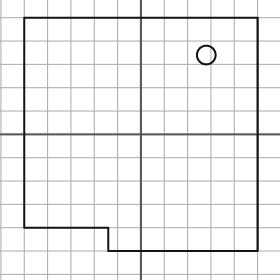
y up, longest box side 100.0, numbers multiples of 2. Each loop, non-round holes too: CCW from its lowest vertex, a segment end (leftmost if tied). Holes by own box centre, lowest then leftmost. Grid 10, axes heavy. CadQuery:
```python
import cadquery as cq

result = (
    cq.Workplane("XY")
    .moveTo(-14.0, -50.0)
    .lineTo(50.0, -50.0)
    .lineTo(50.0, 50.0)
    .lineTo(-50.0, 50.0)
    .lineTo(-50.0, -40.0)
    .lineTo(-14.0, -40.0)
    .close()
    .moveTo(28.0, 34.0)
    .circle(4.0)
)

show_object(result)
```